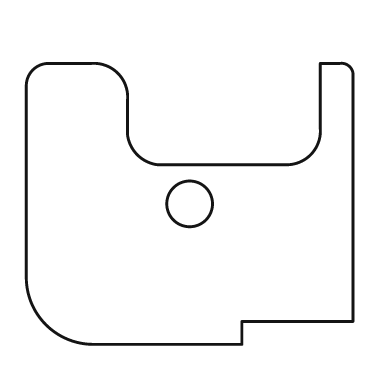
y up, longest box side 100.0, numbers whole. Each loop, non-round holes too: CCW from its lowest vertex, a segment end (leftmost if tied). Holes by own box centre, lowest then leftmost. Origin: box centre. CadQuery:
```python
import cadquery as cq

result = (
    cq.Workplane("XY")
    .moveTo(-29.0, -43.0)
    .lineTo(16.0, -43.0)
    .lineTo(16.0, -36.0)
    .lineTo(50.0, -36.0)
    .lineTo(50.0, 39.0)
    .threePointArc((49.0, 42.0), (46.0, 43.0))
    .lineTo(40.0, 43.0)
    .lineTo(40.0, 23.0)
    .threePointArc((37.0, 15.0), (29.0, 12.0))
    .lineTo(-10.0, 12.0)
    .threePointArc((-16.0, 15.0), (-19.0, 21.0))
    .lineTo(-19.0, 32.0)
    .threePointArc((-22.0, 40.0), (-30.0, 43.0))
    .lineTo(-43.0, 43.0)
    .threePointArc((-48.0, 41.0), (-50.0, 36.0))
    .lineTo(-50.0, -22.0)
    .threePointArc((-44.0, -37.0), (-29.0, -43.0))
    .close()
    .moveTo(0.0, 0.0)
    .circle(7.0)
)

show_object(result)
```